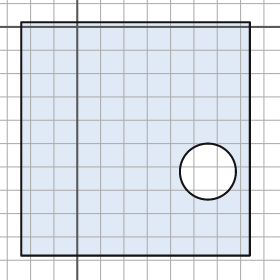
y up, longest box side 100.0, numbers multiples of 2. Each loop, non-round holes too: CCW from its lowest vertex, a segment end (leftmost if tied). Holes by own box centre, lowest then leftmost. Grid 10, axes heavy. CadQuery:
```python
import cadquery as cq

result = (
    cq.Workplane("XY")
    .moveTo(-24.0, -98.0)
    .lineTo(74.0, -98.0)
    .lineTo(74.0, 2.0)
    .lineTo(-24.0, 2.0)
    .close()
    .moveTo(56.0, -62.0)
    .circle(12.0)
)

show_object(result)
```